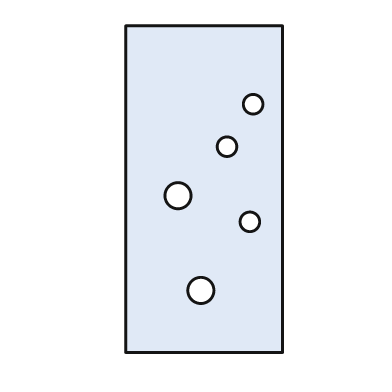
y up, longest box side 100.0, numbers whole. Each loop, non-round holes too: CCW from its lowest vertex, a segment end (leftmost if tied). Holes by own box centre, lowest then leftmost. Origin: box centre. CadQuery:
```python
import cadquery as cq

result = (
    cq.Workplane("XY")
    .moveTo(-24.0, -50.0)
    .lineTo(24.0, -50.0)
    .lineTo(24.0, 50.0)
    .lineTo(-24.0, 50.0)
    .close()
    .moveTo(-1.0, -31.0)
    .circle(4.0)
    .moveTo(14.0, -10.0)
    .circle(3.0)
    .moveTo(-8.0, -2.0)
    .circle(4.0)
    .moveTo(7.0, 13.0)
    .circle(3.0)
    .moveTo(15.0, 26.0)
    .circle(3.0)
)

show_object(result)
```